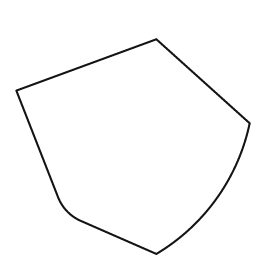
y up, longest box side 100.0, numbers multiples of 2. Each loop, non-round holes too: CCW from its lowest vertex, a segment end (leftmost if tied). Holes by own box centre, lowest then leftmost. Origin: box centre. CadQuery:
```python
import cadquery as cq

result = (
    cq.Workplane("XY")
    .moveTo(10.0, -46.0)
    .threePointArc((36.0, -22.0), (50.0, 10.0))
    .lineTo(10.0, 46.0)
    .lineTo(-50.0, 24.0)
    .lineTo(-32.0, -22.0)
    .threePointArc((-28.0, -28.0), (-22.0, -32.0))
    .close()
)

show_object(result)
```